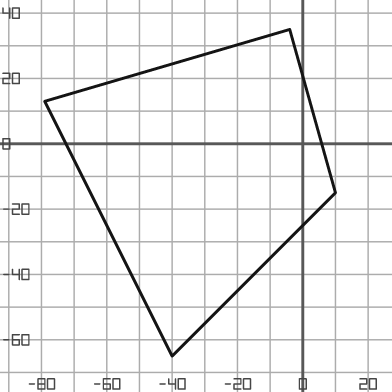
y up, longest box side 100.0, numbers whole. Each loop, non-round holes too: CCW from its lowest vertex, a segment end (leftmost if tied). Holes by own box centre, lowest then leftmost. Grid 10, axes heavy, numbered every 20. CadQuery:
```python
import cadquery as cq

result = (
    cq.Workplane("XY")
    .moveTo(-40.0, -65.0)
    .lineTo(10.0, -15.0)
    .lineTo(-4.0, 35.0)
    .lineTo(-79.0, 13.0)
    .close()
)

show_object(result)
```